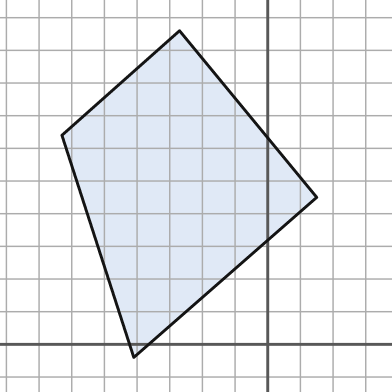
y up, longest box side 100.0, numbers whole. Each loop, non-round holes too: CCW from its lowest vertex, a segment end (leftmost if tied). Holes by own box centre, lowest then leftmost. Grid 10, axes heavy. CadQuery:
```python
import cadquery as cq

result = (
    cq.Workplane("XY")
    .moveTo(-41.0, -4.0)
    .lineTo(15.0, 45.0)
    .lineTo(-27.0, 96.0)
    .lineTo(-63.0, 64.0)
    .close()
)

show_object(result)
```